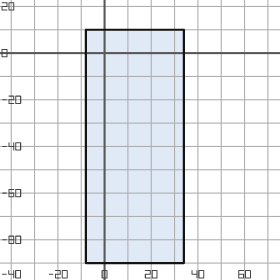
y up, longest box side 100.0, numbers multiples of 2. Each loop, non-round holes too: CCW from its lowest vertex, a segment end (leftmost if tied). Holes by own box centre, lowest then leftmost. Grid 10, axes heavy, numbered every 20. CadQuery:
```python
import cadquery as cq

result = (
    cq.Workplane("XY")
    .moveTo(-8.0, -90.0)
    .lineTo(34.0, -90.0)
    .lineTo(34.0, 10.0)
    .lineTo(-8.0, 10.0)
    .close()
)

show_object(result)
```